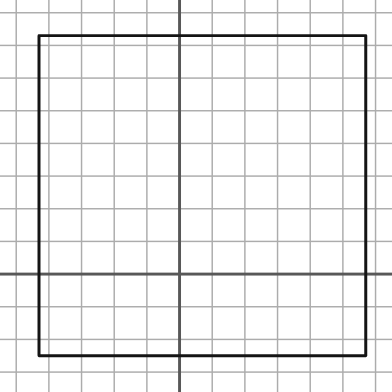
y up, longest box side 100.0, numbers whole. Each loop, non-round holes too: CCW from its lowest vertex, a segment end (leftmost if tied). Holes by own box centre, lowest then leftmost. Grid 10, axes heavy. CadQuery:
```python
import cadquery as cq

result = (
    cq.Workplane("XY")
    .moveTo(-43.0, -25.0)
    .lineTo(57.0, -25.0)
    .lineTo(57.0, 73.0)
    .lineTo(-43.0, 73.0)
    .close()
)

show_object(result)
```